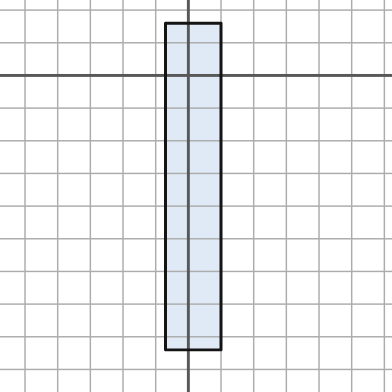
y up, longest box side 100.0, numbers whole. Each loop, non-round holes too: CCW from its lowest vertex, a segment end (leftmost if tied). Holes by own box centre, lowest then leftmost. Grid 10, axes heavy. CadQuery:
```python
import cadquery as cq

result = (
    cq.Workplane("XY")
    .moveTo(-7.0, -84.0)
    .lineTo(10.0, -84.0)
    .lineTo(10.0, 16.0)
    .lineTo(-7.0, 16.0)
    .close()
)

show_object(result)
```